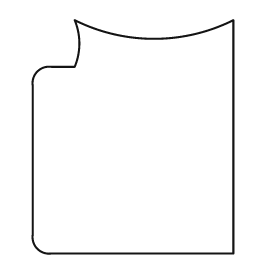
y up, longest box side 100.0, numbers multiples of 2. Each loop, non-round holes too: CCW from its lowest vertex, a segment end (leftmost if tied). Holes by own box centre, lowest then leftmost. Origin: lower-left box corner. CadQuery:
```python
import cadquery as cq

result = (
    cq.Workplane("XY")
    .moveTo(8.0, 0.0)
    .lineTo(86.0, 0.0)
    .lineTo(86.0, 100.0)
    .threePointArc((52.0, 92.0), (18.0, 100.0))
    .threePointArc((20.0, 90.0), (18.0, 80.0))
    .lineTo(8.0, 80.0)
    .threePointArc((2.0, 78.0), (0.0, 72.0))
    .lineTo(0.0, 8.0)
    .threePointArc((2.0, 2.0), (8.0, 0.0))
    .close()
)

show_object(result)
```